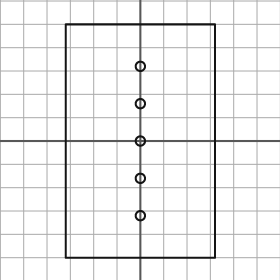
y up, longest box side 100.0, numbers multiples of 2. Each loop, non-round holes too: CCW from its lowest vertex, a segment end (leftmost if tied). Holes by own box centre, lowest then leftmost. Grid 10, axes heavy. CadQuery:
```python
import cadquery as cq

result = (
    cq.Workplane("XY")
    .moveTo(-32.0, -50.0)
    .lineTo(32.0, -50.0)
    .lineTo(32.0, 50.0)
    .lineTo(-32.0, 50.0)
    .close()
    .moveTo(0.0, -32.0)
    .circle(2.0)
    .moveTo(0.0, -16.0)
    .circle(2.0)
    .moveTo(0.0, 0.0)
    .circle(2.0)
    .moveTo(0.0, 16.0)
    .circle(2.0)
    .moveTo(0.0, 32.0)
    .circle(2.0)
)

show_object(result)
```